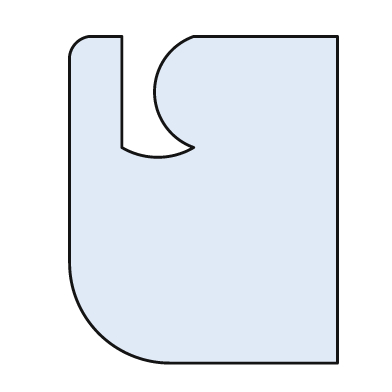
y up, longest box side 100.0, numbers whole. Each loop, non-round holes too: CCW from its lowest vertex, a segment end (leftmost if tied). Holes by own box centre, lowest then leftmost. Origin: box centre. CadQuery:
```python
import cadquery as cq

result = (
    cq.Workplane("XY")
    .moveTo(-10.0, -50.0)
    .lineTo(41.0, -50.0)
    .lineTo(41.0, 50.0)
    .lineTo(-3.0, 50.0)
    .threePointArc((-15.0, 33.0), (-3.0, 16.0))
    .threePointArc((-14.0, 13.0), (-25.0, 16.0))
    .lineTo(-25.0, 50.0)
    .lineTo(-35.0, 50.0)
    .threePointArc((-39.0, 48.0), (-41.0, 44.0))
    .lineTo(-41.0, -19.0)
    .threePointArc((-32.0, -41.0), (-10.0, -50.0))
    .close()
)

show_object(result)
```